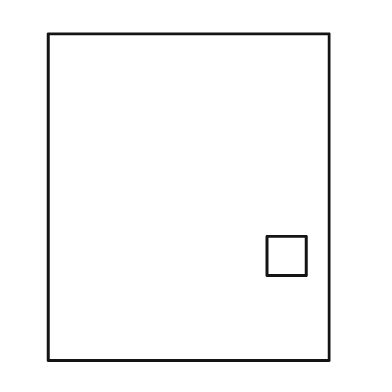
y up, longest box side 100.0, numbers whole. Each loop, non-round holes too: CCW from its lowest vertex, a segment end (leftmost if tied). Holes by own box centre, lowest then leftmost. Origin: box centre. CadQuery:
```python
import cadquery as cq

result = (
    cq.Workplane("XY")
    .moveTo(-43.0, -50.0)
    .lineTo(43.0, -50.0)
    .lineTo(43.0, 50.0)
    .lineTo(-43.0, 50.0)
    .close()
    .moveTo(24.0, -24.0)
    .lineTo(36.0, -24.0)
    .lineTo(36.0, -12.0)
    .lineTo(24.0, -12.0)
    .close()
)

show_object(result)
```